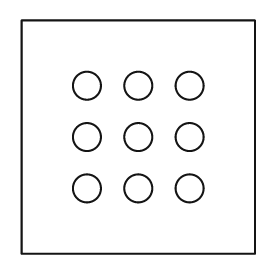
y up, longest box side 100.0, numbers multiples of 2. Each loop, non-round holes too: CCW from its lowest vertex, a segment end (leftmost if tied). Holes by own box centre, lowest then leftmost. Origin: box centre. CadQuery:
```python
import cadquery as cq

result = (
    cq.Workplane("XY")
    .moveTo(-50.0, -50.0)
    .lineTo(50.0, -50.0)
    .lineTo(50.0, 50.0)
    .lineTo(-50.0, 50.0)
    .close()
    .moveTo(-22.0, -22.0)
    .circle(6.0)
    .moveTo(0.0, -22.0)
    .circle(6.0)
    .moveTo(22.0, -22.0)
    .circle(6.0)
    .moveTo(-22.0, 0.0)
    .circle(6.0)
    .moveTo(0.0, 0.0)
    .circle(6.0)
    .moveTo(22.0, 0.0)
    .circle(6.0)
    .moveTo(-22.0, 22.0)
    .circle(6.0)
    .moveTo(0.0, 22.0)
    .circle(6.0)
    .moveTo(22.0, 22.0)
    .circle(6.0)
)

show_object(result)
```